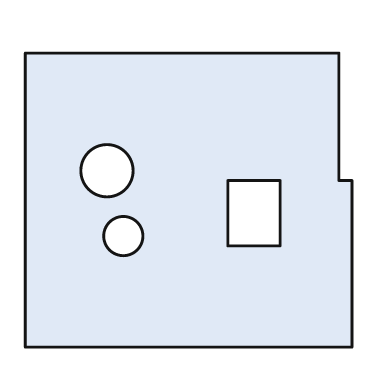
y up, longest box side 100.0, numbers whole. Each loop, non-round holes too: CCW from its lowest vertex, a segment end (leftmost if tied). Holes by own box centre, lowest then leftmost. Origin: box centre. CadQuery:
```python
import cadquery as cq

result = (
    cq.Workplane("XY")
    .moveTo(-50.0, -45.0)
    .lineTo(50.0, -45.0)
    .lineTo(50.0, 6.0)
    .lineTo(46.0, 6.0)
    .lineTo(46.0, 45.0)
    .lineTo(-50.0, 45.0)
    .close()
    .moveTo(-20.0, -11.0)
    .circle(6.0)
    .moveTo(12.0, -14.0)
    .lineTo(28.0, -14.0)
    .lineTo(28.0, 6.0)
    .lineTo(12.0, 6.0)
    .close()
    .moveTo(-25.0, 9.0)
    .circle(8.0)
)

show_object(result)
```